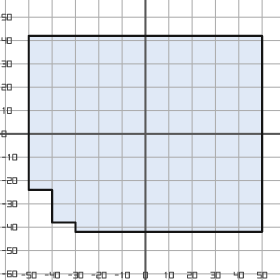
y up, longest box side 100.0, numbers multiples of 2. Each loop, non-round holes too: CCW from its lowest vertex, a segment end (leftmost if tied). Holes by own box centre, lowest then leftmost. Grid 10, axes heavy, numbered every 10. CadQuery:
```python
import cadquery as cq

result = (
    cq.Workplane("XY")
    .moveTo(-30.0, -42.0)
    .lineTo(50.0, -42.0)
    .lineTo(50.0, 42.0)
    .lineTo(-50.0, 42.0)
    .lineTo(-50.0, -24.0)
    .lineTo(-40.0, -24.0)
    .lineTo(-40.0, -38.0)
    .lineTo(-30.0, -38.0)
    .close()
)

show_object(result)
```